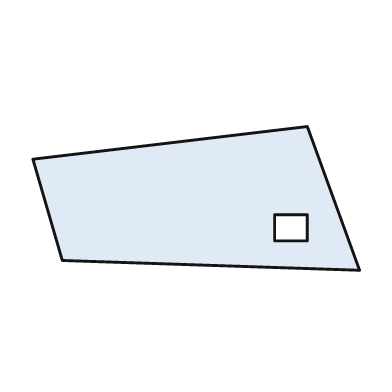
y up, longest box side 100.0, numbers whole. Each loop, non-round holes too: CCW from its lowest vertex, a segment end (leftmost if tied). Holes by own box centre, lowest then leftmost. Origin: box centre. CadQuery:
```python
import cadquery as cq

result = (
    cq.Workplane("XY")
    .moveTo(50.0, -22.0)
    .lineTo(34.0, 22.0)
    .lineTo(-50.0, 12.0)
    .lineTo(-41.0, -19.0)
    .close()
    .moveTo(24.0, -13.0)
    .lineTo(34.0, -13.0)
    .lineTo(34.0, -5.0)
    .lineTo(24.0, -5.0)
    .close()
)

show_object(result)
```